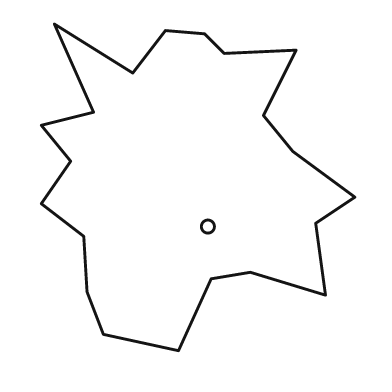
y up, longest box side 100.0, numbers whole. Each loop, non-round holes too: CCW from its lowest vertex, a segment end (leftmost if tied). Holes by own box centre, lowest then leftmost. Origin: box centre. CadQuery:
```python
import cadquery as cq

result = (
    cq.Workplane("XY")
    .moveTo(-6.0, -50.0)
    .lineTo(4.0, -28.0)
    .lineTo(16.0, -26.0)
    .lineTo(39.0, -33.0)
    .lineTo(36.0, -11.0)
    .lineTo(48.0, -3.0)
    .lineTo(29.0, 11.0)
    .lineTo(20.0, 22.0)
    .lineTo(30.0, 42.0)
    .lineTo(8.0, 41.0)
    .lineTo(2.0, 47.0)
    .lineTo(-10.0, 48.0)
    .lineTo(-20.0, 35.0)
    .lineTo(-44.0, 50.0)
    .lineTo(-32.0, 23.0)
    .lineTo(-48.0, 19.0)
    .lineTo(-39.0, 8.0)
    .lineTo(-48.0, -5.0)
    .lineTo(-35.0, -15.0)
    .lineTo(-34.0, -32.0)
    .lineTo(-29.0, -45.0)
    .close()
    .moveTo(3.0, -12.0)
    .circle(2.0)
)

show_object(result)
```